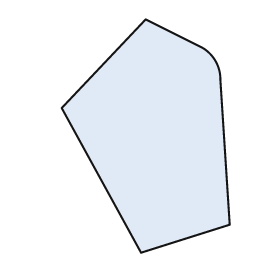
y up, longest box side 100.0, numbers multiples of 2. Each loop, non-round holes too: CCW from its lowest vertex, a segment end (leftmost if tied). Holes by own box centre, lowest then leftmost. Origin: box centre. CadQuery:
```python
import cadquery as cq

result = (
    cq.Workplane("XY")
    .moveTo(-2.0, -50.0)
    .lineTo(36.0, -38.0)
    .lineTo(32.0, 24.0)
    .threePointArc((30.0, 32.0), (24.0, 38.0))
    .lineTo(0.0, 50.0)
    .lineTo(-36.0, 12.0)
    .close()
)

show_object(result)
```